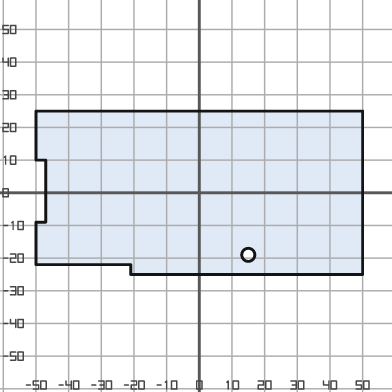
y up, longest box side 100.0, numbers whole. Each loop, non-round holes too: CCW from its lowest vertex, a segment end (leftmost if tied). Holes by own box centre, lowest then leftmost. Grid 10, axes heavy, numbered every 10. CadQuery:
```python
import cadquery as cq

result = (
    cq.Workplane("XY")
    .moveTo(-21.0, -25.0)
    .lineTo(50.0, -25.0)
    .lineTo(50.0, 25.0)
    .lineTo(-50.0, 25.0)
    .lineTo(-50.0, 10.0)
    .lineTo(-47.0, 10.0)
    .lineTo(-47.0, -9.0)
    .lineTo(-50.0, -9.0)
    .lineTo(-50.0, -22.0)
    .lineTo(-21.0, -22.0)
    .close()
    .moveTo(15.0, -19.0)
    .circle(2.0)
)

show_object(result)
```